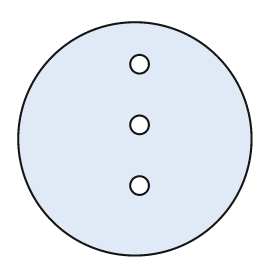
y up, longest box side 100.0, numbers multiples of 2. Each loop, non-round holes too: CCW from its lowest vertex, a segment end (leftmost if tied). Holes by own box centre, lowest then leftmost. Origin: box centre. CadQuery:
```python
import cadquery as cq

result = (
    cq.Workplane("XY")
    .moveTo(0.0, 0.0)
    .circle(50.0)
    .moveTo(2.0, -20.0)
    .circle(4.0)
    .moveTo(2.0, 6.0)
    .circle(4.0)
    .moveTo(2.0, 32.0)
    .circle(4.0)
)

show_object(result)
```